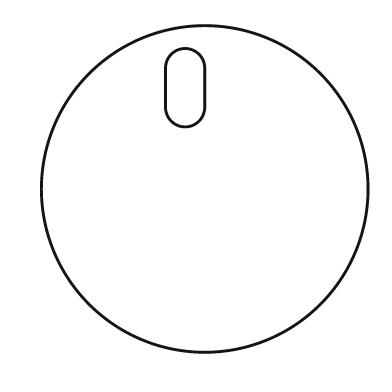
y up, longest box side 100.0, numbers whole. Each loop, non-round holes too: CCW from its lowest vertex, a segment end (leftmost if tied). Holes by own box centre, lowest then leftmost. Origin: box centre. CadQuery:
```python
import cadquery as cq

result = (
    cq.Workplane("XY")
    .moveTo(0.0, 0.0)
    .circle(50.0)
    .moveTo(-12.0, 25.0)
    .threePointArc((-6.0, 19.0), (0.0, 25.0))
    .lineTo(0.0, 37.0)
    .threePointArc((-6.0, 43.0), (-12.0, 37.0))
    .close()
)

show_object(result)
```